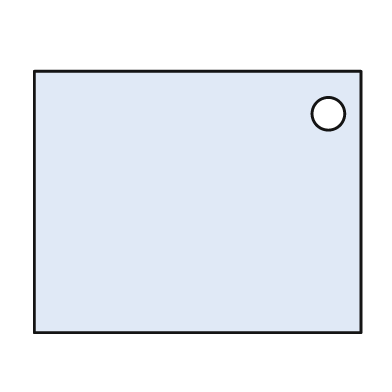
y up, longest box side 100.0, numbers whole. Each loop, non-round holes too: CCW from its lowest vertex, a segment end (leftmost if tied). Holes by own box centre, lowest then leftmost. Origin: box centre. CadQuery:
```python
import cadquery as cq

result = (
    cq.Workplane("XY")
    .moveTo(-50.0, -40.0)
    .lineTo(50.0, -40.0)
    .lineTo(50.0, 40.0)
    .lineTo(-50.0, 40.0)
    .close()
    .moveTo(40.0, 27.0)
    .circle(5.0)
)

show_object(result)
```